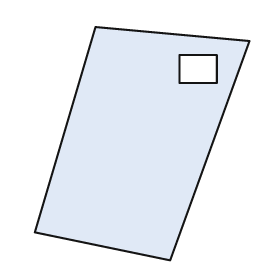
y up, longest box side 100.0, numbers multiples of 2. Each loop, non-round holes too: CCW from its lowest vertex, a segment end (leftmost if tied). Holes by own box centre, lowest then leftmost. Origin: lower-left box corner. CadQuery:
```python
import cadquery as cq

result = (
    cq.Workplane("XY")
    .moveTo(58.0, 0.0)
    .lineTo(92.0, 94.0)
    .lineTo(26.0, 100.0)
    .lineTo(0.0, 12.0)
    .close()
    .moveTo(62.0, 76.0)
    .lineTo(78.0, 76.0)
    .lineTo(78.0, 88.0)
    .lineTo(62.0, 88.0)
    .close()
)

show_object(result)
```